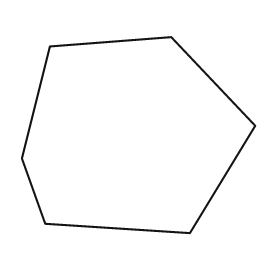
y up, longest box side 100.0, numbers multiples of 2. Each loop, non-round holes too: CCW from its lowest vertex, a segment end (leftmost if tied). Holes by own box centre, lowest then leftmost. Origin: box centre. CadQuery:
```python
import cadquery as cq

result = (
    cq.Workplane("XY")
    .moveTo(22.0, -42.0)
    .lineTo(50.0, 4.0)
    .lineTo(14.0, 42.0)
    .lineTo(-38.0, 38.0)
    .lineTo(-50.0, -10.0)
    .lineTo(-40.0, -38.0)
    .close()
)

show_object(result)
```